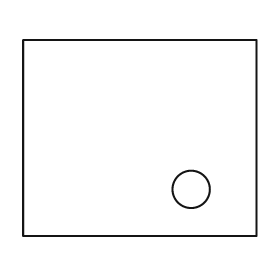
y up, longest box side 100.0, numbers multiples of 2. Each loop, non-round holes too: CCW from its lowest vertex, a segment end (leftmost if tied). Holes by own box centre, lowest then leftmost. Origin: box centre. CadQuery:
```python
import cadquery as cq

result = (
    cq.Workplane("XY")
    .moveTo(-50.0, -42.0)
    .lineTo(50.0, -42.0)
    .lineTo(50.0, 42.0)
    .lineTo(-50.0, 42.0)
    .close()
    .moveTo(22.0, -22.0)
    .circle(8.0)
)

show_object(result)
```